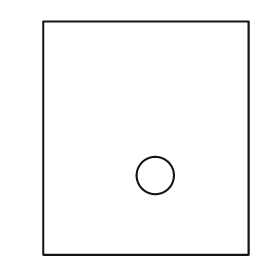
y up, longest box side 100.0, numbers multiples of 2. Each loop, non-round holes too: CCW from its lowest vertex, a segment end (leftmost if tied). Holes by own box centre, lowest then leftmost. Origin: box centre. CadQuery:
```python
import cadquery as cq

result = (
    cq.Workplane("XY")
    .moveTo(-44.0, -50.0)
    .lineTo(44.0, -50.0)
    .lineTo(44.0, 50.0)
    .lineTo(-44.0, 50.0)
    .close()
    .moveTo(4.0, -16.0)
    .circle(8.0)
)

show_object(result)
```